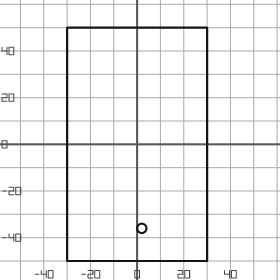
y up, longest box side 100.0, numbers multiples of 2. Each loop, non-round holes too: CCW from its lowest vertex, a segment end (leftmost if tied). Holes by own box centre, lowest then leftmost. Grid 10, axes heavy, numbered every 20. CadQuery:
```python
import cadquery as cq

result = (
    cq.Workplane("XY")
    .moveTo(-30.0, -50.0)
    .lineTo(30.0, -50.0)
    .lineTo(30.0, 50.0)
    .lineTo(-30.0, 50.0)
    .close()
    .moveTo(2.0, -36.0)
    .circle(2.0)
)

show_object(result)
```